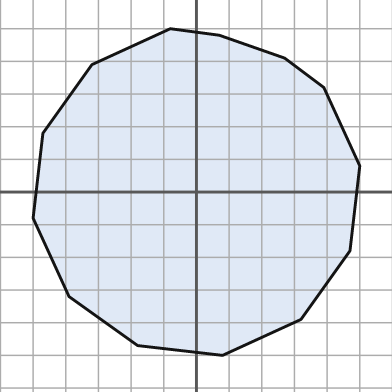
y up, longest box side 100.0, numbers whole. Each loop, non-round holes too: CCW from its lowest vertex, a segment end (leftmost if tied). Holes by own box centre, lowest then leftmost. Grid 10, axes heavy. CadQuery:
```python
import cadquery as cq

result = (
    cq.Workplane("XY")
    .moveTo(8.0, -50.0)
    .lineTo(32.0, -39.0)
    .lineTo(47.0, -18.0)
    .lineTo(50.0, 8.0)
    .lineTo(39.0, 32.0)
    .lineTo(27.0, 41.0)
    .lineTo(7.0, 48.0)
    .lineTo(-8.0, 50.0)
    .lineTo(-32.0, 39.0)
    .lineTo(-47.0, 18.0)
    .lineTo(-50.0, -8.0)
    .lineTo(-39.0, -32.0)
    .lineTo(-18.0, -47.0)
    .close()
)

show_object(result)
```